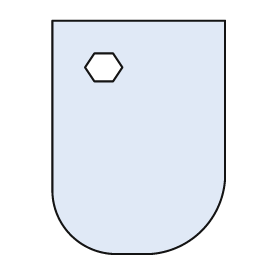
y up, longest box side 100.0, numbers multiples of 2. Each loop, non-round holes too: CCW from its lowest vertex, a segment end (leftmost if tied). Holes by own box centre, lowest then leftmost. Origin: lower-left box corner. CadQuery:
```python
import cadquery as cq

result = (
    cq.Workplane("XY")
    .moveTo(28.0, 0.0)
    .lineTo(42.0, 0.0)
    .threePointArc((64.0, 10.0), (74.0, 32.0))
    .lineTo(74.0, 100.0)
    .lineTo(0.0, 100.0)
    .lineTo(0.0, 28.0)
    .threePointArc((8.0, 8.0), (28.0, 0.0))
    .close()
    .moveTo(18.0, 74.0)
    .lineTo(26.0, 74.0)
    .lineTo(30.0, 80.0)
    .lineTo(26.0, 86.0)
    .lineTo(18.0, 86.0)
    .lineTo(14.0, 80.0)
    .close()
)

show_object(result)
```